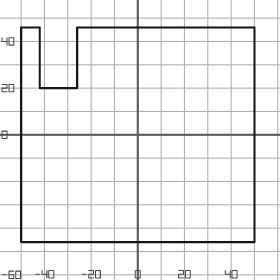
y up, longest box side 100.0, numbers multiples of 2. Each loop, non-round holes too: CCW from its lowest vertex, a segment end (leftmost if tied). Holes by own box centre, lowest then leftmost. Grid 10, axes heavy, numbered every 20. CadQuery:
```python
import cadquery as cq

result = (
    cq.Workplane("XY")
    .moveTo(-50.0, -46.0)
    .lineTo(50.0, -46.0)
    .lineTo(50.0, 46.0)
    .lineTo(-26.0, 46.0)
    .lineTo(-26.0, 20.0)
    .lineTo(-42.0, 20.0)
    .lineTo(-42.0, 46.0)
    .lineTo(-50.0, 46.0)
    .close()
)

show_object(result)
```